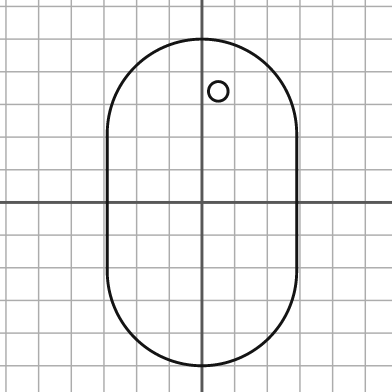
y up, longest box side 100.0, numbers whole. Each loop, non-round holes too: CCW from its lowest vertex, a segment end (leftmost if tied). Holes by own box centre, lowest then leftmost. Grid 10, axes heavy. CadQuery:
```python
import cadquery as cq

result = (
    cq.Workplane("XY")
    .moveTo(-29.0, -21.0)
    .threePointArc((0.0, -50.0), (29.0, -21.0))
    .lineTo(29.0, 21.0)
    .threePointArc((0.0, 50.0), (-29.0, 21.0))
    .close()
    .moveTo(5.0, 34.0)
    .circle(3.0)
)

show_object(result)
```